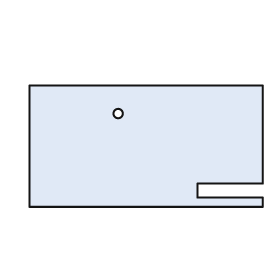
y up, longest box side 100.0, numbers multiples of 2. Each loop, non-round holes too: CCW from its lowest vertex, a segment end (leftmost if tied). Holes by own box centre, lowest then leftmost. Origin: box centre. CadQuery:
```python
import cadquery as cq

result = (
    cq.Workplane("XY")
    .moveTo(-50.0, -26.0)
    .lineTo(50.0, -26.0)
    .lineTo(50.0, -22.0)
    .lineTo(22.0, -22.0)
    .lineTo(22.0, -16.0)
    .lineTo(50.0, -16.0)
    .lineTo(50.0, 26.0)
    .lineTo(-50.0, 26.0)
    .close()
    .moveTo(-12.0, 14.0)
    .circle(2.0)
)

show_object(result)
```